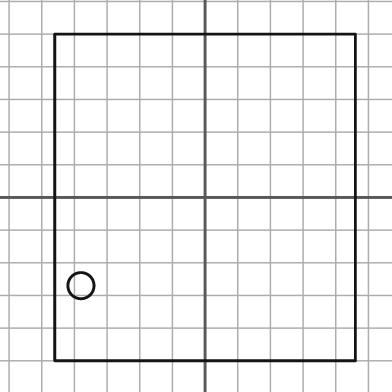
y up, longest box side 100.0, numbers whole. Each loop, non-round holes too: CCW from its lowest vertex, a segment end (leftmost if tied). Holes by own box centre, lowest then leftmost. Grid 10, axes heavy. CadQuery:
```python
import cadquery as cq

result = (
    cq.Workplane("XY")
    .moveTo(-46.0, -50.0)
    .lineTo(46.0, -50.0)
    .lineTo(46.0, 50.0)
    .lineTo(-46.0, 50.0)
    .close()
    .moveTo(-38.0, -27.0)
    .circle(4.0)
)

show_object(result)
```